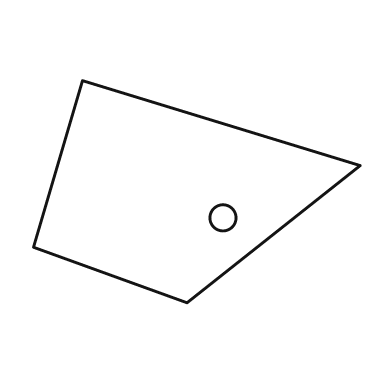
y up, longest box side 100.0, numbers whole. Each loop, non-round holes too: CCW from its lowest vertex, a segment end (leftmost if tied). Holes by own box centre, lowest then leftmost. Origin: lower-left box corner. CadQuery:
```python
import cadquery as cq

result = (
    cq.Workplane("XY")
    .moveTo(47.0, 0.0)
    .lineTo(100.0, 42.0)
    .lineTo(15.0, 68.0)
    .lineTo(0.0, 17.0)
    .close()
    .moveTo(58.0, 26.0)
    .circle(4.0)
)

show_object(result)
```